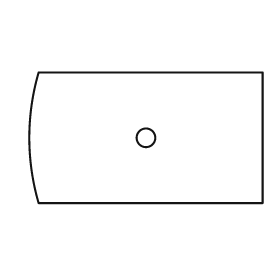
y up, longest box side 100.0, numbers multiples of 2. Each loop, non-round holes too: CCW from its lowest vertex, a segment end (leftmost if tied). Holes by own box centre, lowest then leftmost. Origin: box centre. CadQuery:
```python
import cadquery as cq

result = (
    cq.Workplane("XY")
    .moveTo(-46.0, -28.0)
    .lineTo(50.0, -28.0)
    .lineTo(50.0, 28.0)
    .lineTo(-46.0, 28.0)
    .threePointArc((-50.0, 0.0), (-46.0, -28.0))
    .close()
    .moveTo(0.0, 0.0)
    .circle(4.0)
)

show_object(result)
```